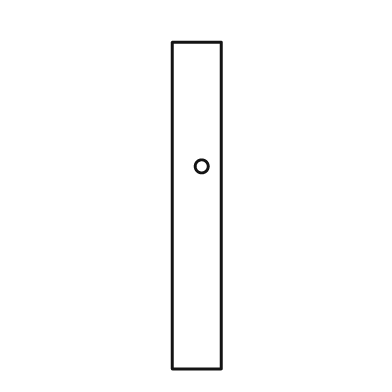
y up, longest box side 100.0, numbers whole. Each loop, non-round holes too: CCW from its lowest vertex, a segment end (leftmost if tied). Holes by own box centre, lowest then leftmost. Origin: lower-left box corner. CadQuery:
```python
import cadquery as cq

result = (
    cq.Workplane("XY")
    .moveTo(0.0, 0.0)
    .lineTo(15.0, 0.0)
    .lineTo(15.0, 100.0)
    .lineTo(0.0, 100.0)
    .close()
    .moveTo(9.0, 62.0)
    .circle(2.0)
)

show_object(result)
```